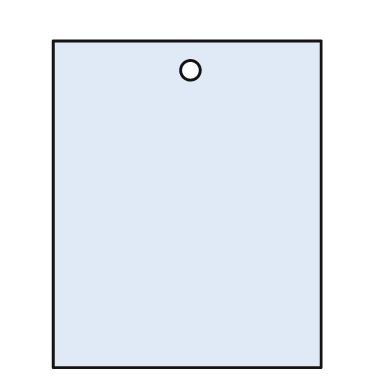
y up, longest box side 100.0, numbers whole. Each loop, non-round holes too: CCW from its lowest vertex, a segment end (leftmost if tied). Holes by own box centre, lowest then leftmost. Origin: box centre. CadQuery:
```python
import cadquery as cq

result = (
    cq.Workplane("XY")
    .moveTo(-41.0, -50.0)
    .lineTo(41.0, -50.0)
    .lineTo(41.0, 50.0)
    .lineTo(-41.0, 50.0)
    .close()
    .moveTo(1.0, 41.0)
    .circle(3.0)
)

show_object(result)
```